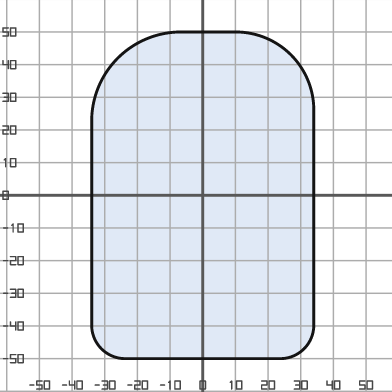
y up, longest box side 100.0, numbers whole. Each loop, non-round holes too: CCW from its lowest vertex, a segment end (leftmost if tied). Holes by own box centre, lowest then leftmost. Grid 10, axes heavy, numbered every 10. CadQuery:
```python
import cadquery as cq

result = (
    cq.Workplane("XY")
    .moveTo(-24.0, -50.0)
    .lineTo(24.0, -50.0)
    .threePointArc((31.0, -47.0), (34.0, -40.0))
    .lineTo(34.0, 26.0)
    .threePointArc((27.0, 43.0), (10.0, 50.0))
    .lineTo(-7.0, 50.0)
    .threePointArc((-26.0, 42.0), (-34.0, 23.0))
    .lineTo(-34.0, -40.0)
    .threePointArc((-31.0, -47.0), (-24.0, -50.0))
    .close()
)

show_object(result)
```